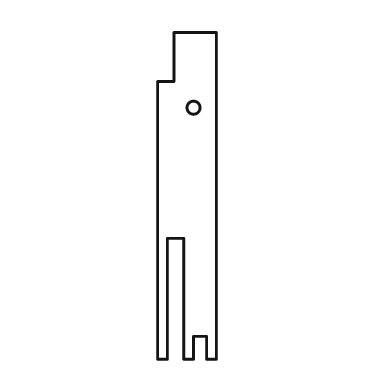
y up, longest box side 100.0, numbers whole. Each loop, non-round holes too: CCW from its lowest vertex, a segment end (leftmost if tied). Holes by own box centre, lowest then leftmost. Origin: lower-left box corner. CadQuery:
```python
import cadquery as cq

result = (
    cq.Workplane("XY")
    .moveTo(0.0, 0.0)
    .lineTo(3.0, 0.0)
    .lineTo(3.0, 37.0)
    .lineTo(8.0, 37.0)
    .lineTo(8.0, 0.0)
    .lineTo(11.0, 0.0)
    .lineTo(11.0, 7.0)
    .lineTo(15.0, 7.0)
    .lineTo(15.0, 0.0)
    .lineTo(18.0, 0.0)
    .lineTo(18.0, 100.0)
    .lineTo(5.0, 100.0)
    .lineTo(5.0, 85.0)
    .lineTo(0.0, 85.0)
    .close()
    .moveTo(11.0, 77.0)
    .circle(2.0)
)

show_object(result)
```